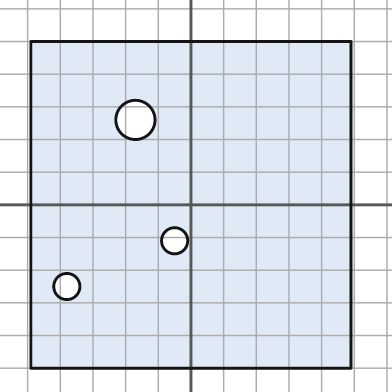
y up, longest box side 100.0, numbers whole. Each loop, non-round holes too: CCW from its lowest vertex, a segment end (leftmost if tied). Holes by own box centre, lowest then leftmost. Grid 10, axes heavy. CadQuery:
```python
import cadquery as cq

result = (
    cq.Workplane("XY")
    .moveTo(-49.0, -50.0)
    .lineTo(49.0, -50.0)
    .lineTo(49.0, 50.0)
    .lineTo(-49.0, 50.0)
    .close()
    .moveTo(-38.0, -25.0)
    .circle(4.0)
    .moveTo(-5.0, -11.0)
    .circle(4.0)
    .moveTo(-17.0, 26.0)
    .circle(6.0)
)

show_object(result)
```